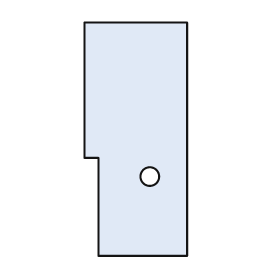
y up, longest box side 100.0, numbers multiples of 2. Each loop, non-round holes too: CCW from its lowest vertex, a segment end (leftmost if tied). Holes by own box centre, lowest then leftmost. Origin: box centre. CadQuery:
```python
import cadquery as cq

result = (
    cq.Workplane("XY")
    .moveTo(-16.0, -50.0)
    .lineTo(22.0, -50.0)
    .lineTo(22.0, 50.0)
    .lineTo(-22.0, 50.0)
    .lineTo(-22.0, -8.0)
    .lineTo(-16.0, -8.0)
    .close()
    .moveTo(6.0, -16.0)
    .circle(4.0)
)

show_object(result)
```